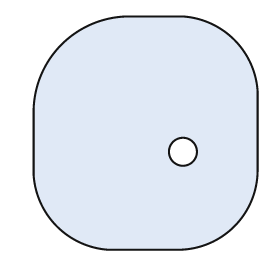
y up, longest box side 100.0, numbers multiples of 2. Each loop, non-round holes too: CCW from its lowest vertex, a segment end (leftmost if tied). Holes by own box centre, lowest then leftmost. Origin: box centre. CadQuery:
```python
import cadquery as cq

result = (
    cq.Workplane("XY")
    .moveTo(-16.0, -50.0)
    .lineTo(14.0, -50.0)
    .threePointArc((38.0, -40.0), (48.0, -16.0))
    .lineTo(48.0, 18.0)
    .threePointArc((38.0, 40.0), (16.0, 50.0))
    .lineTo(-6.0, 50.0)
    .threePointArc((-36.0, 38.0), (-48.0, 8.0))
    .lineTo(-48.0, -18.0)
    .threePointArc((-38.0, -40.0), (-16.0, -50.0))
    .close()
    .moveTo(16.0, -8.0)
    .circle(6.0)
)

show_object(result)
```